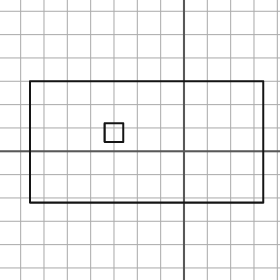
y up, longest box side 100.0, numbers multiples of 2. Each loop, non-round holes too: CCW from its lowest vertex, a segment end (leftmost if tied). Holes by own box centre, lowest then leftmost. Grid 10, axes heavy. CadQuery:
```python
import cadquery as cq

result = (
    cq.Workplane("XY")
    .moveTo(-66.0, -22.0)
    .lineTo(34.0, -22.0)
    .lineTo(34.0, 30.0)
    .lineTo(-66.0, 30.0)
    .close()
    .moveTo(-34.0, 4.0)
    .lineTo(-26.0, 4.0)
    .lineTo(-26.0, 12.0)
    .lineTo(-34.0, 12.0)
    .close()
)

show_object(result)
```